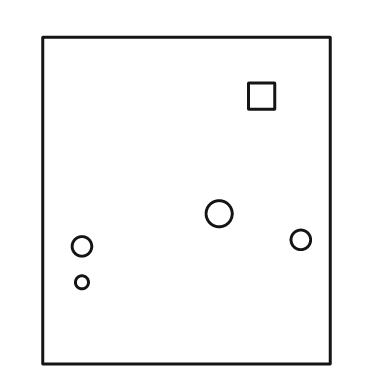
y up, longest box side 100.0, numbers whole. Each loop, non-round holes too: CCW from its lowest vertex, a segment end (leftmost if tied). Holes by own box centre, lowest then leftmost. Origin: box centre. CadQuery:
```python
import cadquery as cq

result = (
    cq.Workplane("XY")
    .moveTo(-44.0, -50.0)
    .lineTo(44.0, -50.0)
    .lineTo(44.0, 50.0)
    .lineTo(-44.0, 50.0)
    .close()
    .moveTo(-32.0, -25.0)
    .circle(2.0)
    .moveTo(-32.0, -14.0)
    .circle(3.0)
    .moveTo(35.0, -12.0)
    .circle(3.0)
    .moveTo(10.0, -4.0)
    .circle(4.0)
    .moveTo(19.0, 28.0)
    .lineTo(27.0, 28.0)
    .lineTo(27.0, 36.0)
    .lineTo(19.0, 36.0)
    .close()
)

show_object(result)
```